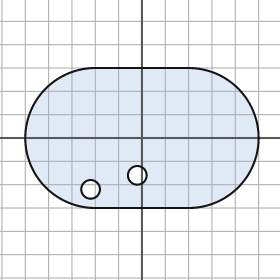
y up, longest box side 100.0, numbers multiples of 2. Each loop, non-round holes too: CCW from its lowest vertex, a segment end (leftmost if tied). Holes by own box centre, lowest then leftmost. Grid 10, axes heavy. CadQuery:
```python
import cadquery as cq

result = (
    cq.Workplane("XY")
    .moveTo(-20.0, -30.0)
    .lineTo(20.0, -30.0)
    .threePointArc((50.0, 0.0), (20.0, 30.0))
    .lineTo(-20.0, 30.0)
    .threePointArc((-50.0, 0.0), (-20.0, -30.0))
    .close()
    .moveTo(-22.0, -22.0)
    .circle(4.0)
    .moveTo(-2.0, -16.0)
    .circle(4.0)
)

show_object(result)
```